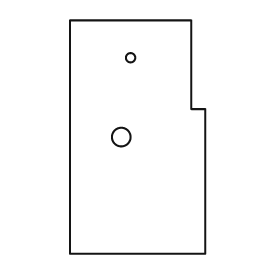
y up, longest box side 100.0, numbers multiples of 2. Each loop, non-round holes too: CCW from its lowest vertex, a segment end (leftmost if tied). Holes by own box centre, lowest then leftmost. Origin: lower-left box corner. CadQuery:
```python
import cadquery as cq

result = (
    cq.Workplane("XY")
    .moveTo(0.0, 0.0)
    .lineTo(58.0, 0.0)
    .lineTo(58.0, 62.0)
    .lineTo(52.0, 62.0)
    .lineTo(52.0, 100.0)
    .lineTo(0.0, 100.0)
    .close()
    .moveTo(22.0, 50.0)
    .circle(4.0)
    .moveTo(26.0, 84.0)
    .circle(2.0)
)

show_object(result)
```